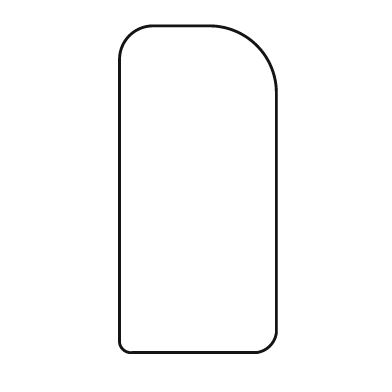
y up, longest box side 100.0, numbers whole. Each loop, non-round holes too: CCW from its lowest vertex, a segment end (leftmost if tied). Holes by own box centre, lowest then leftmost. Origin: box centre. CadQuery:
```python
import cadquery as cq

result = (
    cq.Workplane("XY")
    .moveTo(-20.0, -50.0)
    .lineTo(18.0, -50.0)
    .threePointArc((22.0, -48.0), (24.0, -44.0))
    .lineTo(24.0, 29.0)
    .threePointArc((18.0, 44.0), (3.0, 50.0))
    .lineTo(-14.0, 50.0)
    .threePointArc((-21.0, 47.0), (-24.0, 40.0))
    .lineTo(-24.0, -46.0)
    .threePointArc((-23.0, -49.0), (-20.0, -50.0))
    .close()
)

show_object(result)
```